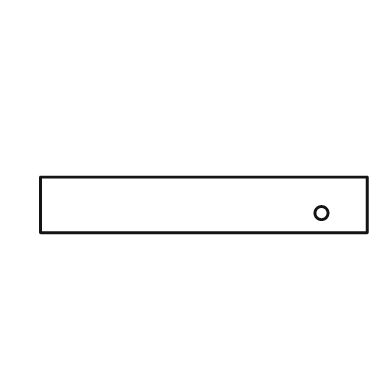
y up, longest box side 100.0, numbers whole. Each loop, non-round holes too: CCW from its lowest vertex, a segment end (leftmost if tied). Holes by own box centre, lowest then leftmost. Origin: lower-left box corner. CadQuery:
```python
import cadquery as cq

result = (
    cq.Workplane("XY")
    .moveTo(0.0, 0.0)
    .lineTo(100.0, 0.0)
    .lineTo(100.0, 17.0)
    .lineTo(0.0, 17.0)
    .close()
    .moveTo(86.0, 6.0)
    .circle(2.0)
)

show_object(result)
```